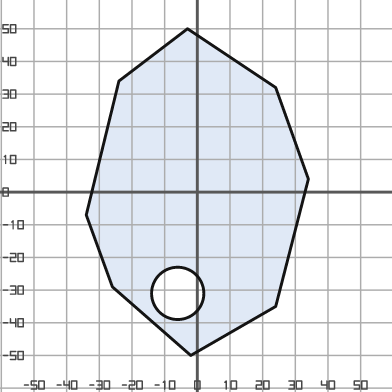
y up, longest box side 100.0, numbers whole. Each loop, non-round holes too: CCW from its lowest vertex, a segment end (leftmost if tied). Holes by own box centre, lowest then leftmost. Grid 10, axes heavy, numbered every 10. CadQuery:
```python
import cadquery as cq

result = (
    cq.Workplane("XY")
    .moveTo(-2.0, -50.0)
    .lineTo(24.0, -35.0)
    .lineTo(34.0, 4.0)
    .lineTo(24.0, 32.0)
    .lineTo(-3.0, 50.0)
    .lineTo(-24.0, 34.0)
    .lineTo(-34.0, -7.0)
    .lineTo(-26.0, -29.0)
    .close()
    .moveTo(-6.0, -31.0)
    .circle(8.0)
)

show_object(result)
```